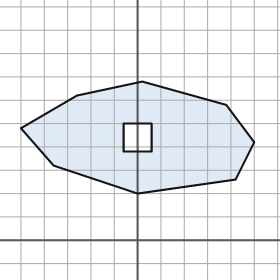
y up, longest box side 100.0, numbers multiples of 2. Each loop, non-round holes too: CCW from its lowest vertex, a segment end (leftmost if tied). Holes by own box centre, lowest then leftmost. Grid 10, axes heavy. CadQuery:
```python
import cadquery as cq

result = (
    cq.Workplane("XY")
    .moveTo(0.0, 20.0)
    .lineTo(42.0, 26.0)
    .lineTo(50.0, 42.0)
    .lineTo(38.0, 58.0)
    .lineTo(2.0, 68.0)
    .lineTo(-26.0, 62.0)
    .lineTo(-50.0, 48.0)
    .lineTo(-36.0, 32.0)
    .close()
    .moveTo(-6.0, 38.0)
    .lineTo(6.0, 38.0)
    .lineTo(6.0, 50.0)
    .lineTo(-6.0, 50.0)
    .close()
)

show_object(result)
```